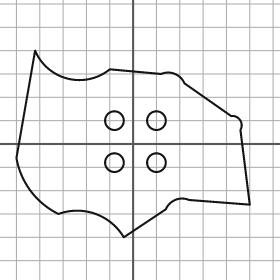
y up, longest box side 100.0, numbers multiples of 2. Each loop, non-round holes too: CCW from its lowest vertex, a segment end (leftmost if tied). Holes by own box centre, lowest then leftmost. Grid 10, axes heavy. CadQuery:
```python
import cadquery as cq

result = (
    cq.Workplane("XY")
    .moveTo(-4.0, -40.0)
    .lineTo(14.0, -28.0)
    .threePointArc((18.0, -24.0), (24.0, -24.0))
    .lineTo(50.0, -26.0)
    .lineTo(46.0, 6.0)
    .threePointArc((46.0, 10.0), (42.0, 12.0))
    .lineTo(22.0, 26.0)
    .threePointArc((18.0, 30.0), (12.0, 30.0))
    .lineTo(-10.0, 32.0)
    .threePointArc((-28.0, 28.0), (-42.0, 40.0))
    .lineTo(-50.0, -6.0)
    .threePointArc((-44.0, -20.0), (-32.0, -30.0))
    .threePointArc((-16.0, -30.0), (-4.0, -40.0))
    .close()
    .moveTo(-8.0, -8.0)
    .circle(4.0)
    .moveTo(10.0, -8.0)
    .circle(4.0)
    .moveTo(-8.0, 10.0)
    .circle(4.0)
    .moveTo(10.0, 10.0)
    .circle(4.0)
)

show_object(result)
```